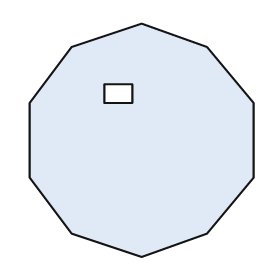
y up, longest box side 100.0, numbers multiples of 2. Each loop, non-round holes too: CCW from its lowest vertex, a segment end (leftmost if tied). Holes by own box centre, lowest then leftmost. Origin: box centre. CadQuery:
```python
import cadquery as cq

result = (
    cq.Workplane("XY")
    .moveTo(0.0, -50.0)
    .lineTo(28.0, -40.0)
    .lineTo(48.0, -16.0)
    .lineTo(48.0, 16.0)
    .lineTo(28.0, 40.0)
    .lineTo(0.0, 50.0)
    .lineTo(-30.0, 40.0)
    .lineTo(-48.0, 16.0)
    .lineTo(-48.0, -16.0)
    .lineTo(-30.0, -40.0)
    .close()
    .moveTo(-16.0, 16.0)
    .lineTo(-4.0, 16.0)
    .lineTo(-4.0, 24.0)
    .lineTo(-16.0, 24.0)
    .close()
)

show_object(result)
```